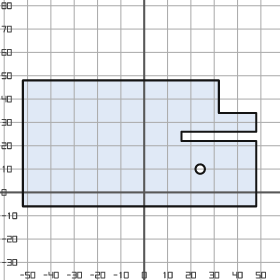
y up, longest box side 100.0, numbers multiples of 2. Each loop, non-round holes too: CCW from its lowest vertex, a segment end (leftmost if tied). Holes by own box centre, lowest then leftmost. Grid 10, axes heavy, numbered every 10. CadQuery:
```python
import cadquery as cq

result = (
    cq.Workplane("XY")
    .moveTo(-52.0, -6.0)
    .lineTo(48.0, -6.0)
    .lineTo(48.0, 22.0)
    .lineTo(16.0, 22.0)
    .lineTo(16.0, 26.0)
    .lineTo(48.0, 26.0)
    .lineTo(48.0, 34.0)
    .lineTo(32.0, 34.0)
    .lineTo(32.0, 48.0)
    .lineTo(-52.0, 48.0)
    .close()
    .moveTo(24.0, 10.0)
    .circle(2.0)
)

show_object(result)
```